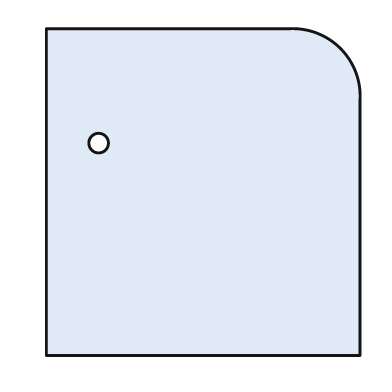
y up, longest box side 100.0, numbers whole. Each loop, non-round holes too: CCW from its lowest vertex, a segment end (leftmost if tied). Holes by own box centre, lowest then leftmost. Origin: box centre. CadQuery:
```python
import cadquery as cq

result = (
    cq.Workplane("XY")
    .moveTo(-48.0, -50.0)
    .lineTo(48.0, -50.0)
    .lineTo(48.0, 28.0)
    .threePointArc((42.0, 44.0), (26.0, 50.0))
    .lineTo(-48.0, 50.0)
    .close()
    .moveTo(-32.0, 15.0)
    .circle(3.0)
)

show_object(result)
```